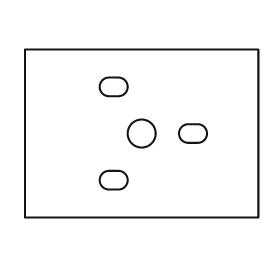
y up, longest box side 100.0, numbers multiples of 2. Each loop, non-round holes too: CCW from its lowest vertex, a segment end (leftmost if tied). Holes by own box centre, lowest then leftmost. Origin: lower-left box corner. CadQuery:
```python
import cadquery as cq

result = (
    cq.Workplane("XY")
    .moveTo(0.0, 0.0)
    .lineTo(100.0, 0.0)
    .lineTo(100.0, 72.0)
    .lineTo(0.0, 72.0)
    .close()
    .moveTo(36.0, 12.0)
    .lineTo(40.0, 12.0)
    .threePointArc((44.0, 16.0), (40.0, 20.0))
    .lineTo(36.0, 20.0)
    .threePointArc((32.0, 16.0), (36.0, 12.0))
    .close()
    .moveTo(50.0, 36.0)
    .circle(6.0)
    .moveTo(70.0, 32.0)
    .lineTo(74.0, 32.0)
    .threePointArc((78.0, 36.0), (74.0, 40.0))
    .lineTo(70.0, 40.0)
    .threePointArc((66.0, 36.0), (70.0, 32.0))
    .close()
    .moveTo(36.0, 52.0)
    .lineTo(40.0, 52.0)
    .threePointArc((44.0, 56.0), (40.0, 60.0))
    .lineTo(36.0, 60.0)
    .threePointArc((32.0, 56.0), (36.0, 52.0))
    .close()
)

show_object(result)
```